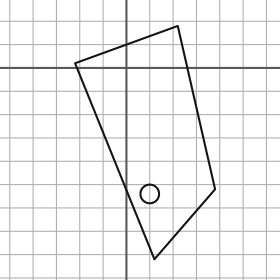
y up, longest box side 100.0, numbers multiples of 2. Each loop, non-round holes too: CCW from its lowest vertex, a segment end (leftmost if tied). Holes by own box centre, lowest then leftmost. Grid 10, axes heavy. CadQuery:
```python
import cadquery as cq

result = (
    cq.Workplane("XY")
    .moveTo(12.0, -82.0)
    .lineTo(38.0, -52.0)
    .lineTo(22.0, 18.0)
    .lineTo(-22.0, 2.0)
    .close()
    .moveTo(10.0, -54.0)
    .circle(4.0)
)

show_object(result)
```